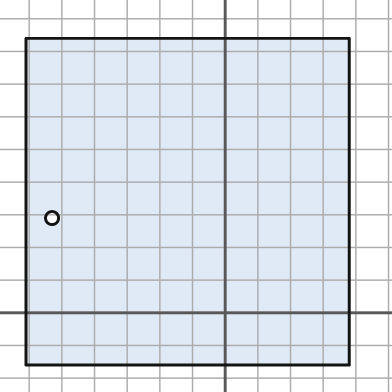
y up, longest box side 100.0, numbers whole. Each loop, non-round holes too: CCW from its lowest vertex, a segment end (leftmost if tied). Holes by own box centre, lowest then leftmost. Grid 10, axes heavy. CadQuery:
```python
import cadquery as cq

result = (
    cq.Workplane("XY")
    .moveTo(-61.0, -16.0)
    .lineTo(38.0, -16.0)
    .lineTo(38.0, 84.0)
    .lineTo(-61.0, 84.0)
    .close()
    .moveTo(-53.0, 29.0)
    .circle(2.0)
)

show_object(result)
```